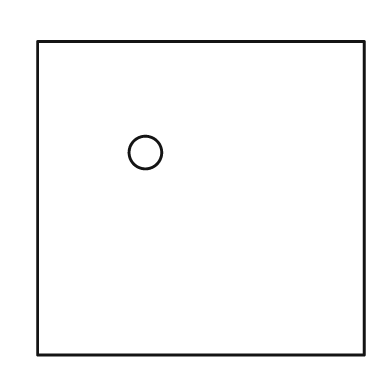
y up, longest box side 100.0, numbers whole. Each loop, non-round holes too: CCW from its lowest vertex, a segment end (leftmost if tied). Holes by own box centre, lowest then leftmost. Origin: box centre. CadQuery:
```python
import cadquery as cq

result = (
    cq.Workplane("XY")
    .moveTo(-50.0, -48.0)
    .lineTo(50.0, -48.0)
    .lineTo(50.0, 48.0)
    .lineTo(-50.0, 48.0)
    .close()
    .moveTo(-17.0, 14.0)
    .circle(5.0)
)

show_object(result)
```